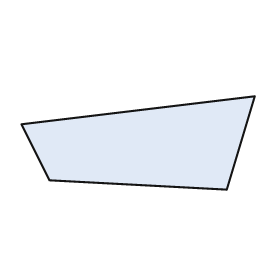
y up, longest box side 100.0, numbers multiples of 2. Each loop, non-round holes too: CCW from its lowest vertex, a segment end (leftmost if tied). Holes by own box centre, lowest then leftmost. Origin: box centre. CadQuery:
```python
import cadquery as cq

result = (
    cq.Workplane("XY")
    .moveTo(38.0, -20.0)
    .lineTo(50.0, 20.0)
    .lineTo(-50.0, 8.0)
    .lineTo(-38.0, -16.0)
    .close()
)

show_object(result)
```